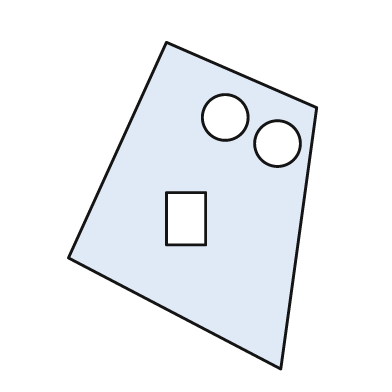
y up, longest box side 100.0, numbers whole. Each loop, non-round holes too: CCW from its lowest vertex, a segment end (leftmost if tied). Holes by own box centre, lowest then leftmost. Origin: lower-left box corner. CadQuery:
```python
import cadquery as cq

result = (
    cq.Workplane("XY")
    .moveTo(65.0, 0.0)
    .lineTo(76.0, 80.0)
    .lineTo(30.0, 100.0)
    .lineTo(0.0, 34.0)
    .close()
    .moveTo(30.0, 38.0)
    .lineTo(42.0, 38.0)
    .lineTo(42.0, 54.0)
    .lineTo(30.0, 54.0)
    .close()
    .moveTo(64.0, 69.0)
    .circle(7.0)
    .moveTo(48.0, 77.0)
    .circle(7.0)
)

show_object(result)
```